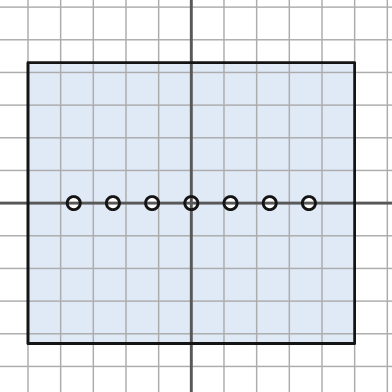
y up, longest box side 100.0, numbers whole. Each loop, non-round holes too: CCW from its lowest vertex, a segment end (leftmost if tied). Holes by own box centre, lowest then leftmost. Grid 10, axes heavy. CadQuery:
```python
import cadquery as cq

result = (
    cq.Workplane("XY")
    .moveTo(-50.0, -43.0)
    .lineTo(50.0, -43.0)
    .lineTo(50.0, 43.0)
    .lineTo(-50.0, 43.0)
    .close()
    .moveTo(-36.0, 0.0)
    .circle(2.0)
    .moveTo(-24.0, 0.0)
    .circle(2.0)
    .moveTo(-12.0, 0.0)
    .circle(2.0)
    .moveTo(0.0, 0.0)
    .circle(2.0)
    .moveTo(12.0, 0.0)
    .circle(2.0)
    .moveTo(24.0, 0.0)
    .circle(2.0)
    .moveTo(36.0, 0.0)
    .circle(2.0)
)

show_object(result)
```